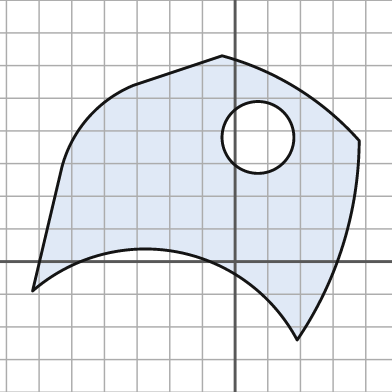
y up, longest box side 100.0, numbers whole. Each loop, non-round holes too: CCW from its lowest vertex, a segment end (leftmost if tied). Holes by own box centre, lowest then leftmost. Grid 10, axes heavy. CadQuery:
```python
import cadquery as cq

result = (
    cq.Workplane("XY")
    .moveTo(19.0, -24.0)
    .threePointArc((33.0, 5.0), (38.0, 37.0))
    .threePointArc((19.0, 53.0), (-4.0, 63.0))
    .lineTo(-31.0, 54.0)
    .threePointArc((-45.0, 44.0), (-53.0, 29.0))
    .lineTo(-62.0, -9.0)
    .threePointArc((-18.0, 3.0), (19.0, -24.0))
    .close()
    .moveTo(7.0, 38.0)
    .circle(11.0)
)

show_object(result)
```